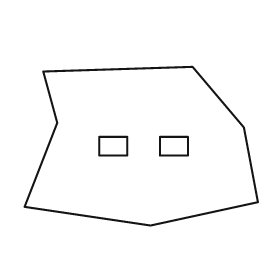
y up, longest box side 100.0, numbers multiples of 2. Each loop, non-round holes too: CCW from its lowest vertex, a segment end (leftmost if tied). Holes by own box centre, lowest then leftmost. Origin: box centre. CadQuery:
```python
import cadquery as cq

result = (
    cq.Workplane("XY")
    .moveTo(4.0, -34.0)
    .lineTo(50.0, -24.0)
    .lineTo(44.0, 8.0)
    .lineTo(22.0, 34.0)
    .lineTo(-42.0, 32.0)
    .lineTo(-36.0, 10.0)
    .lineTo(-50.0, -26.0)
    .close()
    .moveTo(-18.0, -4.0)
    .lineTo(-6.0, -4.0)
    .lineTo(-6.0, 4.0)
    .lineTo(-18.0, 4.0)
    .close()
    .moveTo(8.0, -4.0)
    .lineTo(20.0, -4.0)
    .lineTo(20.0, 4.0)
    .lineTo(8.0, 4.0)
    .close()
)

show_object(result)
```